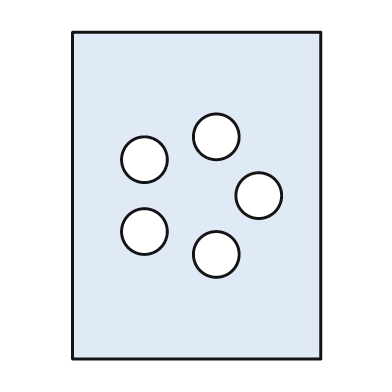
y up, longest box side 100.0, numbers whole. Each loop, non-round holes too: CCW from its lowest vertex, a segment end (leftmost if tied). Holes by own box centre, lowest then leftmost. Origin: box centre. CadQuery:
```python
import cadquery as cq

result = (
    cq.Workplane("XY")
    .moveTo(-38.0, -50.0)
    .lineTo(38.0, -50.0)
    .lineTo(38.0, 50.0)
    .lineTo(-38.0, 50.0)
    .close()
    .moveTo(6.0, -18.0)
    .circle(7.0)
    .moveTo(-16.0, -11.0)
    .circle(7.0)
    .moveTo(19.0, 0.0)
    .circle(7.0)
    .moveTo(-16.0, 11.0)
    .circle(7.0)
    .moveTo(6.0, 18.0)
    .circle(7.0)
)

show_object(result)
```